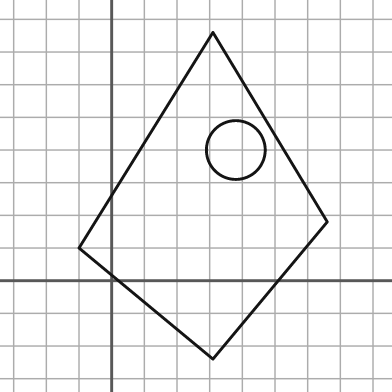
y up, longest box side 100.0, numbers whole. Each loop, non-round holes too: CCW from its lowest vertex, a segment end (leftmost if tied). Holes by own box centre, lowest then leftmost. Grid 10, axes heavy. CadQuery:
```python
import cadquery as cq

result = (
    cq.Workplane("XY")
    .moveTo(31.0, -24.0)
    .lineTo(66.0, 18.0)
    .lineTo(31.0, 76.0)
    .lineTo(-10.0, 10.0)
    .close()
    .moveTo(38.0, 40.0)
    .circle(9.0)
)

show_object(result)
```